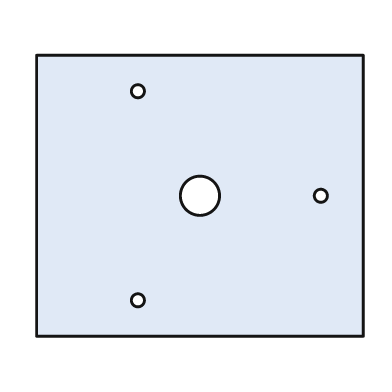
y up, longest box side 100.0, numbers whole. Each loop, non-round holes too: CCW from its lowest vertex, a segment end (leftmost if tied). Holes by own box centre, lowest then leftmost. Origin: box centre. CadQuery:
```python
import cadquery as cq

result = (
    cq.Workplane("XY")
    .moveTo(-50.0, -43.0)
    .lineTo(50.0, -43.0)
    .lineTo(50.0, 43.0)
    .lineTo(-50.0, 43.0)
    .close()
    .moveTo(-19.0, -32.0)
    .circle(2.0)
    .moveTo(0.0, 0.0)
    .circle(6.0)
    .moveTo(37.0, 0.0)
    .circle(2.0)
    .moveTo(-19.0, 32.0)
    .circle(2.0)
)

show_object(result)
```